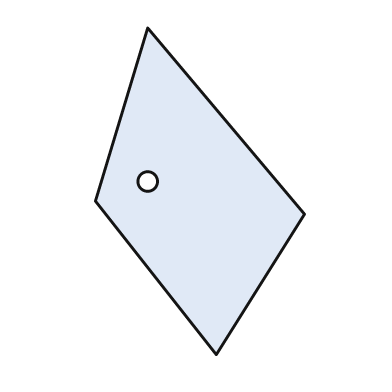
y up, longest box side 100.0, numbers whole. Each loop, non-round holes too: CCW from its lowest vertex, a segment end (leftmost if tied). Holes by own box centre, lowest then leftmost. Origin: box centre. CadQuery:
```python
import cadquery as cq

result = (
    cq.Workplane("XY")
    .moveTo(5.0, -50.0)
    .lineTo(32.0, -7.0)
    .lineTo(-16.0, 50.0)
    .lineTo(-32.0, -3.0)
    .close()
    .moveTo(-16.0, 3.0)
    .circle(3.0)
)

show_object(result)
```